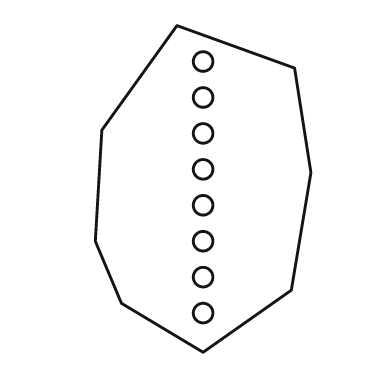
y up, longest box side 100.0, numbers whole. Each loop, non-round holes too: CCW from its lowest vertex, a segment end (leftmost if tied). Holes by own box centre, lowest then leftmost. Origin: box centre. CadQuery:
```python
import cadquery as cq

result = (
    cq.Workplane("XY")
    .moveTo(0.0, -50.0)
    .lineTo(27.0, -31.0)
    .lineTo(33.0, 5.0)
    .lineTo(28.0, 37.0)
    .lineTo(-8.0, 50.0)
    .lineTo(-31.0, 18.0)
    .lineTo(-33.0, -16.0)
    .lineTo(-25.0, -35.0)
    .close()
    .moveTo(0.0, -38.0)
    .circle(3.0)
    .moveTo(0.0, -27.0)
    .circle(3.0)
    .moveTo(0.0, -16.0)
    .circle(3.0)
    .moveTo(0.0, -5.0)
    .circle(3.0)
    .moveTo(0.0, 6.0)
    .circle(3.0)
    .moveTo(0.0, 17.0)
    .circle(3.0)
    .moveTo(0.0, 28.0)
    .circle(3.0)
    .moveTo(0.0, 39.0)
    .circle(3.0)
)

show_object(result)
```